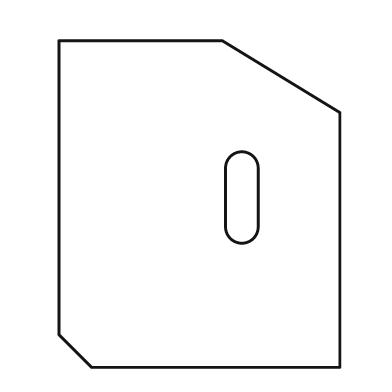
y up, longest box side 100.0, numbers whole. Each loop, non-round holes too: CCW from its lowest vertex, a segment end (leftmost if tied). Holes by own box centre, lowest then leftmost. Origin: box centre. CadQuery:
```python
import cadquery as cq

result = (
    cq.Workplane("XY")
    .moveTo(-33.0, -50.0)
    .lineTo(43.0, -50.0)
    .lineTo(43.0, 28.0)
    .lineTo(7.0, 50.0)
    .lineTo(-43.0, 50.0)
    .lineTo(-43.0, -40.0)
    .close()
    .moveTo(8.0, -7.0)
    .threePointArc((13.0, -12.0), (18.0, -7.0))
    .lineTo(18.0, 11.0)
    .threePointArc((13.0, 16.0), (8.0, 11.0))
    .close()
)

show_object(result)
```